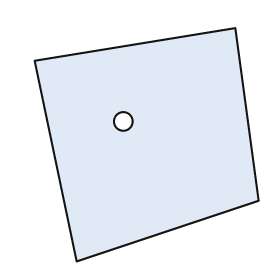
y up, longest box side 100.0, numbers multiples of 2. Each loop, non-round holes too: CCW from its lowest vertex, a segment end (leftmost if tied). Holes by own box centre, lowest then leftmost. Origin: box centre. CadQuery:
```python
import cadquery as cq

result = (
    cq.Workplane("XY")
    .moveTo(-30.0, -50.0)
    .lineTo(48.0, -24.0)
    .lineTo(38.0, 50.0)
    .lineTo(-48.0, 36.0)
    .close()
    .moveTo(-10.0, 10.0)
    .circle(4.0)
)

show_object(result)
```